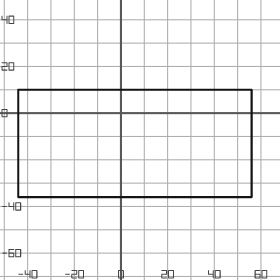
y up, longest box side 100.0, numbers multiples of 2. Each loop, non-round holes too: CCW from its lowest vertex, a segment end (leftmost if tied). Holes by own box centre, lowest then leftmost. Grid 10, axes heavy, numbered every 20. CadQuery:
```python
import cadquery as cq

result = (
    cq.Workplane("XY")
    .moveTo(-44.0, -36.0)
    .lineTo(56.0, -36.0)
    .lineTo(56.0, 10.0)
    .lineTo(-44.0, 10.0)
    .close()
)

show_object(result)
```